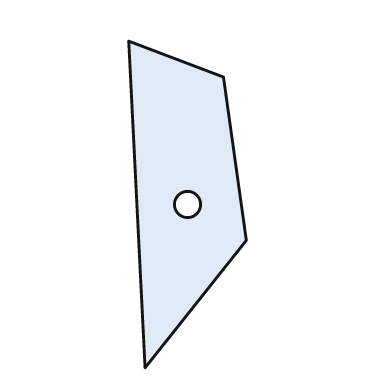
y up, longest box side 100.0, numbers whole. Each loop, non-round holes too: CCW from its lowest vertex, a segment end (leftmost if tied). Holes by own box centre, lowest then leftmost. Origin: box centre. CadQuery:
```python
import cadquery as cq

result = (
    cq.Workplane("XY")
    .moveTo(-13.0, -50.0)
    .lineTo(18.0, -11.0)
    .lineTo(11.0, 39.0)
    .lineTo(-18.0, 50.0)
    .close()
    .moveTo(0.0, 0.0)
    .circle(4.0)
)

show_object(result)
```